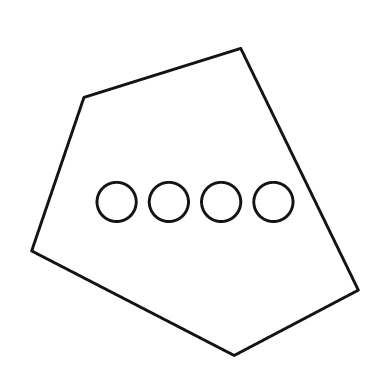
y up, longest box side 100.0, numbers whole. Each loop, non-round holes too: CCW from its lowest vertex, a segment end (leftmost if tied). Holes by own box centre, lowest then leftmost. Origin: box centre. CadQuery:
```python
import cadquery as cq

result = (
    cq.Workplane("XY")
    .moveTo(12.0, -47.0)
    .lineTo(50.0, -27.0)
    .lineTo(14.0, 47.0)
    .lineTo(-34.0, 32.0)
    .lineTo(-50.0, -15.0)
    .close()
    .moveTo(-24.0, 0.0)
    .circle(6.0)
    .moveTo(-8.0, 0.0)
    .circle(6.0)
    .moveTo(8.0, 0.0)
    .circle(6.0)
    .moveTo(24.0, 0.0)
    .circle(6.0)
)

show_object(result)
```